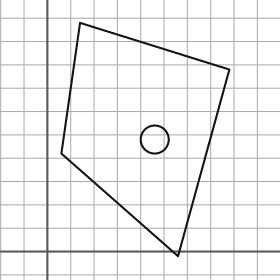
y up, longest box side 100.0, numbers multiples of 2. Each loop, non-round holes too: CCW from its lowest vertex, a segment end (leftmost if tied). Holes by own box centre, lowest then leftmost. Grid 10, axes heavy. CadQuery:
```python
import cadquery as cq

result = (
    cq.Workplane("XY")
    .moveTo(56.0, -2.0)
    .lineTo(78.0, 78.0)
    .lineTo(14.0, 98.0)
    .lineTo(6.0, 42.0)
    .close()
    .moveTo(46.0, 48.0)
    .circle(6.0)
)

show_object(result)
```